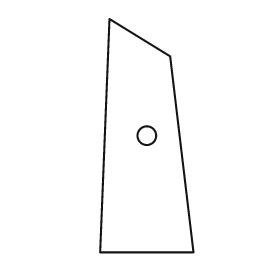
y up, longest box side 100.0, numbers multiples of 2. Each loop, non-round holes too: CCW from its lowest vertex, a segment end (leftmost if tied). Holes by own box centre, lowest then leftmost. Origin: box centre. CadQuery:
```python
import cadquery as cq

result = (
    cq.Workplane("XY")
    .moveTo(-20.0, -50.0)
    .lineTo(20.0, -50.0)
    .lineTo(10.0, 34.0)
    .lineTo(-16.0, 50.0)
    .close()
    .moveTo(0.0, 0.0)
    .circle(4.0)
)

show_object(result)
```